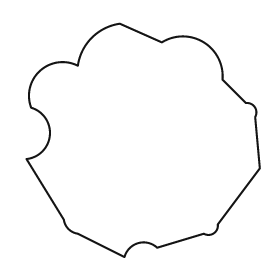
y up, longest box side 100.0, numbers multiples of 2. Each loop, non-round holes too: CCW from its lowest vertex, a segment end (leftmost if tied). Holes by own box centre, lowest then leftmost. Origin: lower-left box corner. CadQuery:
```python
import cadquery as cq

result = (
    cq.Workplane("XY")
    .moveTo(42.0, 0.0)
    .threePointArc((48.0, 6.0), (56.0, 4.0))
    .lineTo(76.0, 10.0)
    .threePointArc((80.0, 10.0), (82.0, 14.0))
    .lineTo(100.0, 38.0)
    .lineTo(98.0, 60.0)
    .threePointArc((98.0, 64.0), (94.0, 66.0))
    .lineTo(84.0, 76.0)
    .threePointArc((76.0, 92.0), (58.0, 92.0))
    .lineTo(40.0, 100.0)
    .threePointArc((28.0, 94.0), (22.0, 82.0))
    .threePointArc((6.0, 80.0), (2.0, 64.0))
    .threePointArc((10.0, 52.0), (0.0, 42.0))
    .lineTo(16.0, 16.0)
    .threePointArc((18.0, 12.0), (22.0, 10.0))
    .close()
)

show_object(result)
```